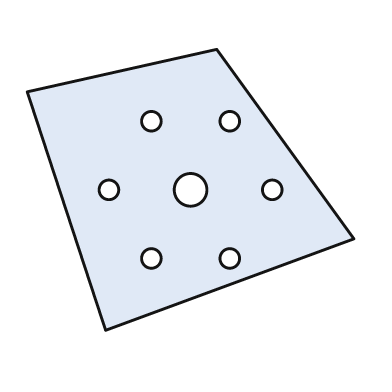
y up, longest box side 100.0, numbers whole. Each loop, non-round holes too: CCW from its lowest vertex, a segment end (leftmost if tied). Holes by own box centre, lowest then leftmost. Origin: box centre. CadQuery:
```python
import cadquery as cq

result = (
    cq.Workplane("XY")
    .moveTo(-26.0, -43.0)
    .lineTo(50.0, -15.0)
    .lineTo(8.0, 43.0)
    .lineTo(-50.0, 30.0)
    .close()
    .moveTo(-12.0, -21.0)
    .circle(3.0)
    .moveTo(12.0, -21.0)
    .circle(3.0)
    .moveTo(-25.0, 0.0)
    .circle(3.0)
    .moveTo(0.0, 0.0)
    .circle(5.0)
    .moveTo(25.0, 0.0)
    .circle(3.0)
    .moveTo(-12.0, 21.0)
    .circle(3.0)
    .moveTo(12.0, 21.0)
    .circle(3.0)
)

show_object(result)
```